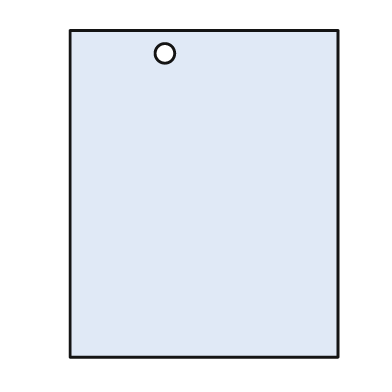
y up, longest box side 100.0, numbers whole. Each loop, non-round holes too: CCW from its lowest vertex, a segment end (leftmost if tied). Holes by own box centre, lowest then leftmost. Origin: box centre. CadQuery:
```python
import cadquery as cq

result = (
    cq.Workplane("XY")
    .moveTo(-41.0, -50.0)
    .lineTo(41.0, -50.0)
    .lineTo(41.0, 50.0)
    .lineTo(-41.0, 50.0)
    .close()
    .moveTo(-12.0, 43.0)
    .circle(3.0)
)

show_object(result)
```